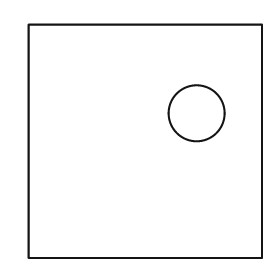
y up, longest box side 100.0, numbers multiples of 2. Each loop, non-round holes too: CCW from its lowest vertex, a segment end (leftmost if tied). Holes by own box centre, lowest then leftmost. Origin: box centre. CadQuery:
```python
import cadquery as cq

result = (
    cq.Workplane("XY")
    .moveTo(-50.0, -50.0)
    .lineTo(50.0, -50.0)
    .lineTo(50.0, 50.0)
    .lineTo(-50.0, 50.0)
    .close()
    .moveTo(22.0, 12.0)
    .circle(12.0)
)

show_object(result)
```